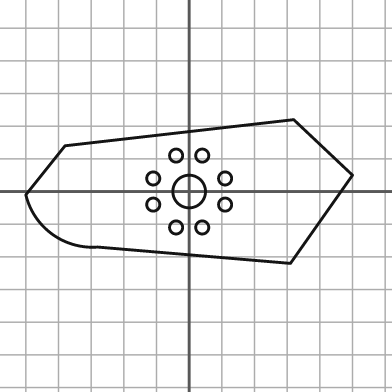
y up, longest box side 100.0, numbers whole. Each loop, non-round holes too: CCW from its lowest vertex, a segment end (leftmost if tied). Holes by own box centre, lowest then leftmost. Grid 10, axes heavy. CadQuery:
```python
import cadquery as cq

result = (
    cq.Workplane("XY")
    .moveTo(31.0, -22.0)
    .lineTo(50.0, 5.0)
    .lineTo(32.0, 22.0)
    .lineTo(-38.0, 14.0)
    .lineTo(-50.0, -1.0)
    .threePointArc((-42.0, -13.0), (-28.0, -17.0))
    .close()
    .moveTo(-4.0, -11.0)
    .circle(2.0)
    .moveTo(4.0, -11.0)
    .circle(2.0)
    .moveTo(-11.0, -4.0)
    .circle(2.0)
    .moveTo(11.0, -4.0)
    .circle(2.0)
    .moveTo(0.0, 0.0)
    .circle(5.0)
    .moveTo(-11.0, 4.0)
    .circle(2.0)
    .moveTo(11.0, 4.0)
    .circle(2.0)
    .moveTo(-4.0, 11.0)
    .circle(2.0)
    .moveTo(4.0, 11.0)
    .circle(2.0)
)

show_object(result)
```